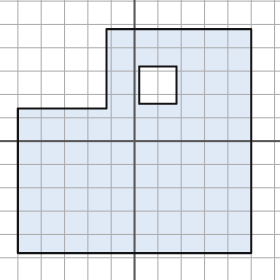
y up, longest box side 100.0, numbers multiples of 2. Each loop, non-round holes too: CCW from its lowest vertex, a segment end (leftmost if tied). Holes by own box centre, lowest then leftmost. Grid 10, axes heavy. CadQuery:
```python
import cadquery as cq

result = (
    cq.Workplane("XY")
    .moveTo(-50.0, -48.0)
    .lineTo(50.0, -48.0)
    .lineTo(50.0, 48.0)
    .lineTo(-12.0, 48.0)
    .lineTo(-12.0, 14.0)
    .lineTo(-50.0, 14.0)
    .close()
    .moveTo(2.0, 16.0)
    .lineTo(18.0, 16.0)
    .lineTo(18.0, 32.0)
    .lineTo(2.0, 32.0)
    .close()
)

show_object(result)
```